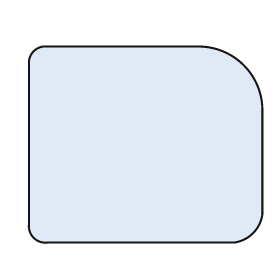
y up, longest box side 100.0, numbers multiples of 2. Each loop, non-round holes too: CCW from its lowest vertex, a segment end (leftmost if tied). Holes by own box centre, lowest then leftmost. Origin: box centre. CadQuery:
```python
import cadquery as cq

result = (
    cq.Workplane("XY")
    .moveTo(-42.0, -42.0)
    .lineTo(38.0, -42.0)
    .threePointArc((46.0, -38.0), (50.0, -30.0))
    .lineTo(50.0, 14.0)
    .threePointArc((42.0, 34.0), (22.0, 42.0))
    .lineTo(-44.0, 42.0)
    .threePointArc((-48.0, 40.0), (-50.0, 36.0))
    .lineTo(-50.0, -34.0)
    .threePointArc((-48.0, -40.0), (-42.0, -42.0))
    .close()
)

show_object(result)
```